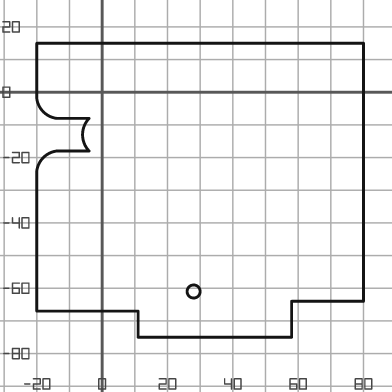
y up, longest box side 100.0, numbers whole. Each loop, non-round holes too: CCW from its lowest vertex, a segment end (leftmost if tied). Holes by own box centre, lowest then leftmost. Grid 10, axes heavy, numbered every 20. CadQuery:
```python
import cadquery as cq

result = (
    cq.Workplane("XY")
    .moveTo(11.0, -75.0)
    .lineTo(58.0, -75.0)
    .lineTo(58.0, -64.0)
    .lineTo(80.0, -64.0)
    .lineTo(80.0, 15.0)
    .lineTo(-20.0, 15.0)
    .lineTo(-20.0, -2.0)
    .threePointArc((-18.0, -6.0), (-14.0, -8.0))
    .lineTo(-4.0, -8.0)
    .threePointArc((-6.0, -13.0), (-4.0, -18.0))
    .lineTo(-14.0, -18.0)
    .threePointArc((-18.0, -20.0), (-20.0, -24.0))
    .lineTo(-20.0, -67.0)
    .lineTo(11.0, -67.0)
    .close()
    .moveTo(28.0, -61.0)
    .circle(2.0)
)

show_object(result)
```